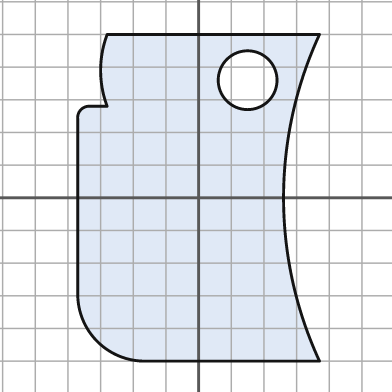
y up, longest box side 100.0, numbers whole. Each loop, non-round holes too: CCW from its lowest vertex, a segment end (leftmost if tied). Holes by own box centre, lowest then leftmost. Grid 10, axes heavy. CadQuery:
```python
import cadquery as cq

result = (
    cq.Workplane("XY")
    .moveTo(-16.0, -50.0)
    .lineTo(37.0, -50.0)
    .threePointArc((26.0, 0.0), (37.0, 50.0))
    .lineTo(-28.0, 50.0)
    .threePointArc((-30.0, 39.0), (-28.0, 28.0))
    .lineTo(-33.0, 28.0)
    .threePointArc((-36.0, 27.0), (-37.0, 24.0))
    .lineTo(-37.0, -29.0)
    .threePointArc((-31.0, -44.0), (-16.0, -50.0))
    .close()
    .moveTo(15.0, 36.0)
    .circle(9.0)
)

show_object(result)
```